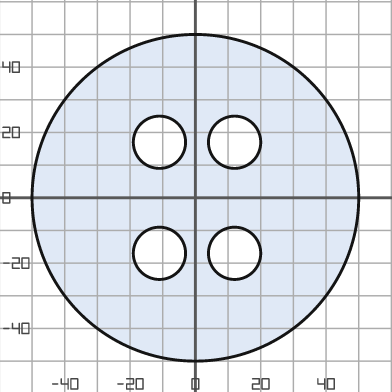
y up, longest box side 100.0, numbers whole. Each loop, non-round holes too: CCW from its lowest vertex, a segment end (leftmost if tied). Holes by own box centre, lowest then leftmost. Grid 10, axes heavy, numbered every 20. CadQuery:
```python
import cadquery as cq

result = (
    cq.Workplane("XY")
    .moveTo(0.0, 0.0)
    .circle(50.0)
    .moveTo(-11.0, -17.0)
    .circle(8.0)
    .moveTo(12.0, -17.0)
    .circle(8.0)
    .moveTo(-11.0, 17.0)
    .circle(8.0)
    .moveTo(12.0, 17.0)
    .circle(8.0)
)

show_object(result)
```